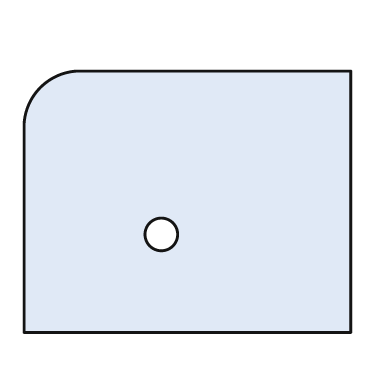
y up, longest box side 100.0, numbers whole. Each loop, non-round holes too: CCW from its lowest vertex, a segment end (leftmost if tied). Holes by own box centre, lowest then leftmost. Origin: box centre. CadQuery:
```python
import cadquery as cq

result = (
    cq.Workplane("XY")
    .moveTo(-50.0, -40.0)
    .lineTo(50.0, -40.0)
    .lineTo(50.0, 40.0)
    .lineTo(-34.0, 40.0)
    .threePointArc((-45.0, 35.0), (-50.0, 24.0))
    .close()
    .moveTo(-8.0, -10.0)
    .circle(5.0)
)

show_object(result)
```